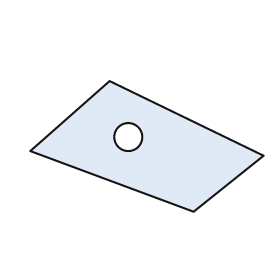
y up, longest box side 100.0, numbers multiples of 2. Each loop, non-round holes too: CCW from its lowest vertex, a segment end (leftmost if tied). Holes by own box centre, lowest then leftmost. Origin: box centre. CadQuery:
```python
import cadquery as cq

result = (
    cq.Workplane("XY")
    .moveTo(20.0, -28.0)
    .lineTo(50.0, -4.0)
    .lineTo(-16.0, 28.0)
    .lineTo(-50.0, -2.0)
    .close()
    .moveTo(-8.0, 4.0)
    .circle(6.0)
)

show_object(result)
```